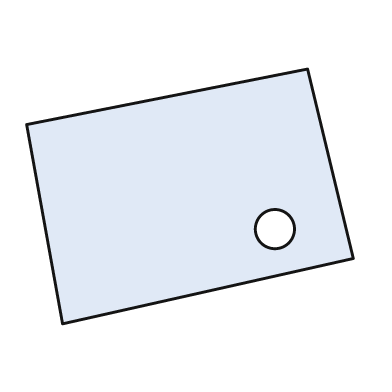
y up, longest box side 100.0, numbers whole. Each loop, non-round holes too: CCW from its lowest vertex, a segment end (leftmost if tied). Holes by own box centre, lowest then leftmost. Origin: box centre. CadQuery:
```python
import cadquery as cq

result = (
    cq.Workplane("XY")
    .moveTo(-39.0, -39.0)
    .lineTo(50.0, -19.0)
    .lineTo(36.0, 39.0)
    .lineTo(-50.0, 22.0)
    .close()
    .moveTo(26.0, -10.0)
    .circle(6.0)
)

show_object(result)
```